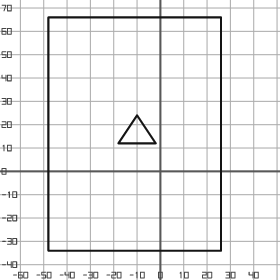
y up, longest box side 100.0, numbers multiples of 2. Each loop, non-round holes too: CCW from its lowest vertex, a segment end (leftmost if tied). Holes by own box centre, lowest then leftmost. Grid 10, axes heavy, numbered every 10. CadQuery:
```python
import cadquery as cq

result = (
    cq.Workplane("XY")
    .moveTo(-48.0, -34.0)
    .lineTo(26.0, -34.0)
    .lineTo(26.0, 66.0)
    .lineTo(-48.0, 66.0)
    .close()
    .moveTo(-18.0, 12.0)
    .lineTo(-2.0, 12.0)
    .lineTo(-10.0, 24.0)
    .close()
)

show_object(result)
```